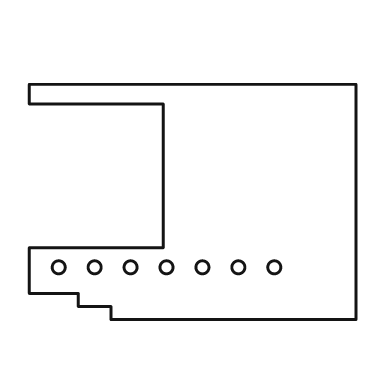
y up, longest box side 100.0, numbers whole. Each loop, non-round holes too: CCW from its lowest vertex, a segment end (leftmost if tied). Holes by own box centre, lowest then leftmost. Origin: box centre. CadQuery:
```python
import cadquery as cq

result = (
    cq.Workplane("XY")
    .moveTo(-25.0, -36.0)
    .lineTo(50.0, -36.0)
    .lineTo(50.0, 36.0)
    .lineTo(-50.0, 36.0)
    .lineTo(-50.0, 30.0)
    .lineTo(-9.0, 30.0)
    .lineTo(-9.0, -14.0)
    .lineTo(-50.0, -14.0)
    .lineTo(-50.0, -28.0)
    .lineTo(-35.0, -28.0)
    .lineTo(-35.0, -32.0)
    .lineTo(-25.0, -32.0)
    .close()
    .moveTo(-41.0, -20.0)
    .circle(2.0)
    .moveTo(-30.0, -20.0)
    .circle(2.0)
    .moveTo(-19.0, -20.0)
    .circle(2.0)
    .moveTo(-8.0, -20.0)
    .circle(2.0)
    .moveTo(3.0, -20.0)
    .circle(2.0)
    .moveTo(14.0, -20.0)
    .circle(2.0)
    .moveTo(25.0, -20.0)
    .circle(2.0)
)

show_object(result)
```